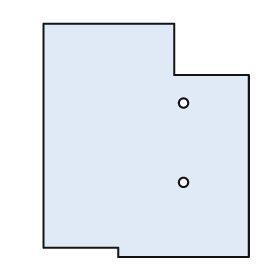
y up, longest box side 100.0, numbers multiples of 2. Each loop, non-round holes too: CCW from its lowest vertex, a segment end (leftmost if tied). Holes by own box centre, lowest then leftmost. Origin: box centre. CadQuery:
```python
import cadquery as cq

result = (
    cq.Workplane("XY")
    .moveTo(-12.0, -50.0)
    .lineTo(44.0, -50.0)
    .lineTo(44.0, 28.0)
    .lineTo(12.0, 28.0)
    .lineTo(12.0, 50.0)
    .lineTo(-44.0, 50.0)
    .lineTo(-44.0, -46.0)
    .lineTo(-12.0, -46.0)
    .close()
    .moveTo(16.0, -18.0)
    .circle(2.0)
    .moveTo(16.0, 16.0)
    .circle(2.0)
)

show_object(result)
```